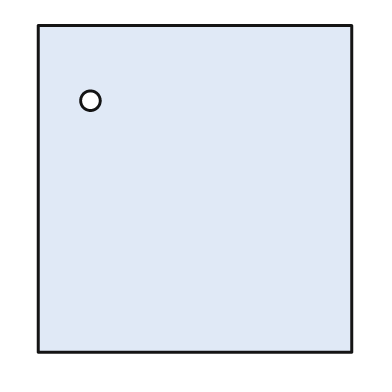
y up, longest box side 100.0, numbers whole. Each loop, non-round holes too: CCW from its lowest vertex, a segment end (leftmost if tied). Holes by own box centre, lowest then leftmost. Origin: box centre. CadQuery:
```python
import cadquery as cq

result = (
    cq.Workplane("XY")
    .moveTo(-48.0, -50.0)
    .lineTo(48.0, -50.0)
    .lineTo(48.0, 50.0)
    .lineTo(-48.0, 50.0)
    .close()
    .moveTo(-32.0, 27.0)
    .circle(3.0)
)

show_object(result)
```